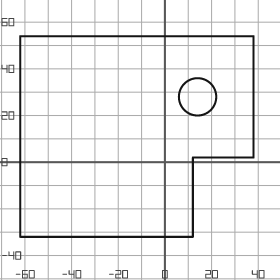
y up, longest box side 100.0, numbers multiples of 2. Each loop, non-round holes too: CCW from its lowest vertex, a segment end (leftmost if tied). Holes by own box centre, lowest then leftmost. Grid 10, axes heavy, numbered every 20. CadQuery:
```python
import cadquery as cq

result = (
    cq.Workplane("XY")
    .moveTo(-62.0, -32.0)
    .lineTo(12.0, -32.0)
    .lineTo(12.0, 2.0)
    .lineTo(38.0, 2.0)
    .lineTo(38.0, 54.0)
    .lineTo(-62.0, 54.0)
    .close()
    .moveTo(14.0, 28.0)
    .circle(8.0)
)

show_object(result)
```